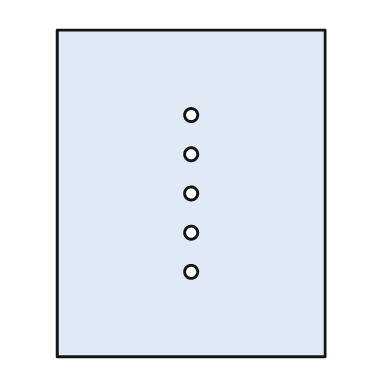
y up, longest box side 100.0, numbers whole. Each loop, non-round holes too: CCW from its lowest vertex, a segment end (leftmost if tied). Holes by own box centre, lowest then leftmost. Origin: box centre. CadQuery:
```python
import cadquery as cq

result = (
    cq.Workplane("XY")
    .moveTo(-41.0, -50.0)
    .lineTo(41.0, -50.0)
    .lineTo(41.0, 50.0)
    .lineTo(-41.0, 50.0)
    .close()
    .moveTo(0.0, -24.0)
    .circle(2.0)
    .moveTo(0.0, -12.0)
    .circle(2.0)
    .moveTo(0.0, 0.0)
    .circle(2.0)
    .moveTo(0.0, 12.0)
    .circle(2.0)
    .moveTo(0.0, 24.0)
    .circle(2.0)
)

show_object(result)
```